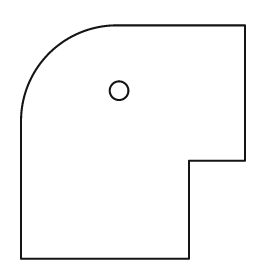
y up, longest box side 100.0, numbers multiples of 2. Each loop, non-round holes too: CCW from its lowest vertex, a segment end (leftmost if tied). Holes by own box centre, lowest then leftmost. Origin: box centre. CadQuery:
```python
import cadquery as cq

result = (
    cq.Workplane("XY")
    .moveTo(-48.0, -50.0)
    .lineTo(24.0, -50.0)
    .lineTo(24.0, -8.0)
    .lineTo(48.0, -8.0)
    .lineTo(48.0, 50.0)
    .lineTo(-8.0, 50.0)
    .threePointArc((-36.0, 38.0), (-48.0, 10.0))
    .close()
    .moveTo(-6.0, 22.0)
    .circle(4.0)
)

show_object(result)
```